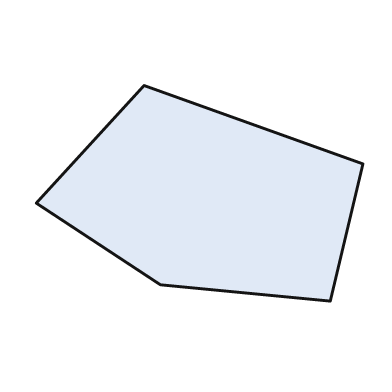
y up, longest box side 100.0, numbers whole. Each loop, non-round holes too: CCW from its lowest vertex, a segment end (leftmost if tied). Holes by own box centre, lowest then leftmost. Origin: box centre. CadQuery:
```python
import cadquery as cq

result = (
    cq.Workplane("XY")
    .moveTo(40.0, -33.0)
    .lineTo(50.0, 9.0)
    .lineTo(-17.0, 33.0)
    .lineTo(-50.0, -3.0)
    .lineTo(-12.0, -28.0)
    .close()
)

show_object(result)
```